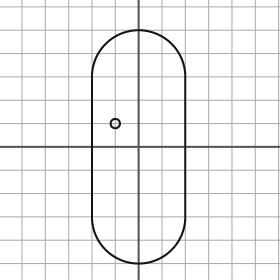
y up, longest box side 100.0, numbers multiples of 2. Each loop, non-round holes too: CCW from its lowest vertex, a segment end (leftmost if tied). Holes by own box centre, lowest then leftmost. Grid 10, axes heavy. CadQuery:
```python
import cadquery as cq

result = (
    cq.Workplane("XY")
    .moveTo(-20.0, -30.0)
    .threePointArc((0.0, -50.0), (20.0, -30.0))
    .lineTo(20.0, 30.0)
    .threePointArc((0.0, 50.0), (-20.0, 30.0))
    .close()
    .moveTo(-10.0, 10.0)
    .circle(2.0)
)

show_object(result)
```